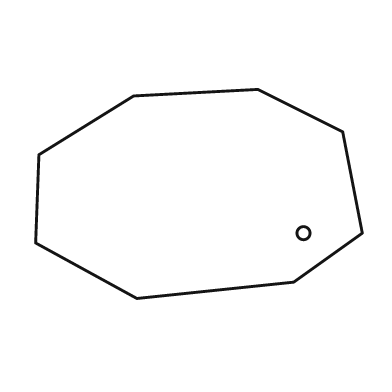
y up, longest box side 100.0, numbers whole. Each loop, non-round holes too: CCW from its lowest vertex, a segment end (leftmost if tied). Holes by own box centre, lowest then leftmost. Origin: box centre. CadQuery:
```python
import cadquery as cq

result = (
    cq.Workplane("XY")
    .moveTo(-19.0, -32.0)
    .lineTo(29.0, -27.0)
    .lineTo(50.0, -12.0)
    .lineTo(44.0, 19.0)
    .lineTo(18.0, 32.0)
    .lineTo(-20.0, 30.0)
    .lineTo(-49.0, 12.0)
    .lineTo(-50.0, -15.0)
    .close()
    .moveTo(32.0, -12.0)
    .circle(2.0)
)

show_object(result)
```